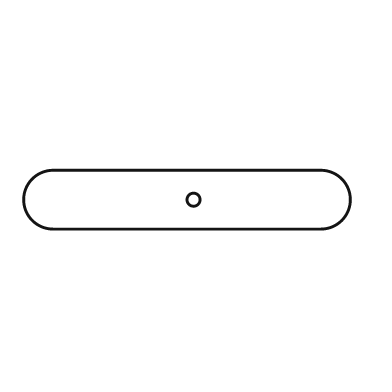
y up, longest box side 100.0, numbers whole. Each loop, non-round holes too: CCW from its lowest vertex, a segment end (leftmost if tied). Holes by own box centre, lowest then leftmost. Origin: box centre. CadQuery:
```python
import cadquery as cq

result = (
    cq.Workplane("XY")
    .moveTo(-41.0, -9.0)
    .lineTo(41.0, -9.0)
    .threePointArc((50.0, 0.0), (41.0, 9.0))
    .lineTo(-41.0, 9.0)
    .threePointArc((-50.0, 0.0), (-41.0, -9.0))
    .close()
    .moveTo(2.0, 0.0)
    .circle(2.0)
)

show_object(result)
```